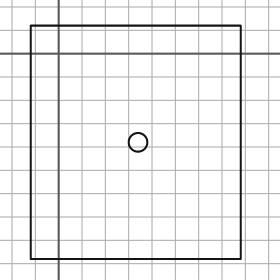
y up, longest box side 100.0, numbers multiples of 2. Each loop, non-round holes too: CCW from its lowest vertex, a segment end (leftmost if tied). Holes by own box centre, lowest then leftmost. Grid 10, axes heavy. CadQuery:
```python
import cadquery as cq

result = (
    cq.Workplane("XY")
    .moveTo(-12.0, -88.0)
    .lineTo(78.0, -88.0)
    .lineTo(78.0, 12.0)
    .lineTo(-12.0, 12.0)
    .close()
    .moveTo(34.0, -38.0)
    .circle(4.0)
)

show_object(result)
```